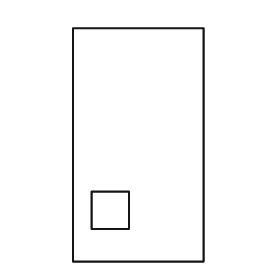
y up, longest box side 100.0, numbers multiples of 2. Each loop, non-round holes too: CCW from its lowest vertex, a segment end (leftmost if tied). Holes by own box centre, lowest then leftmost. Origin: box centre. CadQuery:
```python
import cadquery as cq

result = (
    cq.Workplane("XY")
    .moveTo(-28.0, -50.0)
    .lineTo(28.0, -50.0)
    .lineTo(28.0, 50.0)
    .lineTo(-28.0, 50.0)
    .close()
    .moveTo(-20.0, -36.0)
    .lineTo(-4.0, -36.0)
    .lineTo(-4.0, -20.0)
    .lineTo(-20.0, -20.0)
    .close()
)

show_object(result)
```